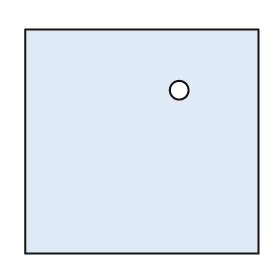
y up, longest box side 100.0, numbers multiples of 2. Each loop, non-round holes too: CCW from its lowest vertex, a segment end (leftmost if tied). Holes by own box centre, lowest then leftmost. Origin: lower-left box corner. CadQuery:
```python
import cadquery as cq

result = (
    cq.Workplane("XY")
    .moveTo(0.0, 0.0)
    .lineTo(100.0, 0.0)
    .lineTo(100.0, 96.0)
    .lineTo(0.0, 96.0)
    .close()
    .moveTo(66.0, 70.0)
    .circle(4.0)
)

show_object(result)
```